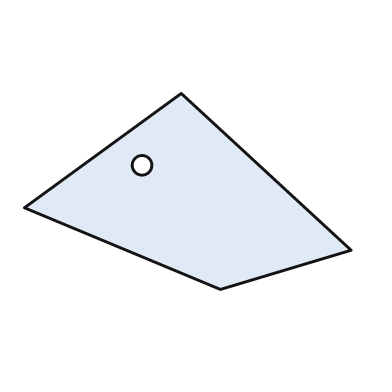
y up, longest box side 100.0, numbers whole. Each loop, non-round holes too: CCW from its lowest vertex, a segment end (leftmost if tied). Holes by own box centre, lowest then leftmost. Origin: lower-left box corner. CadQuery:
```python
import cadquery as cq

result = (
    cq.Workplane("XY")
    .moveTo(60.0, 0.0)
    .lineTo(100.0, 12.0)
    .lineTo(48.0, 60.0)
    .lineTo(0.0, 25.0)
    .close()
    .moveTo(36.0, 38.0)
    .circle(3.0)
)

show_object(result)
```